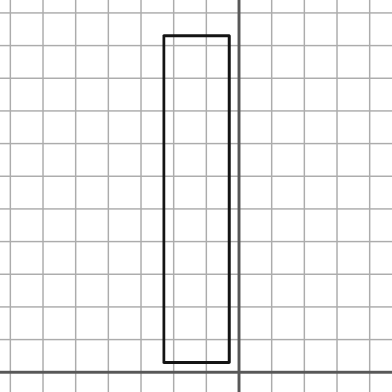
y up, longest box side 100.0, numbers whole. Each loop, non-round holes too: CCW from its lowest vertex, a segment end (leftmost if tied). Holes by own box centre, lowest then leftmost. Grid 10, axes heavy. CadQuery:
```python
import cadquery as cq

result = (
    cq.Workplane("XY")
    .moveTo(-23.0, 3.0)
    .lineTo(-3.0, 3.0)
    .lineTo(-3.0, 103.0)
    .lineTo(-23.0, 103.0)
    .close()
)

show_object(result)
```